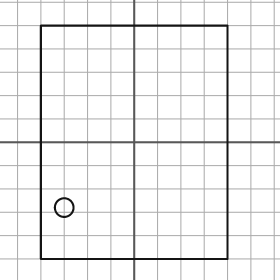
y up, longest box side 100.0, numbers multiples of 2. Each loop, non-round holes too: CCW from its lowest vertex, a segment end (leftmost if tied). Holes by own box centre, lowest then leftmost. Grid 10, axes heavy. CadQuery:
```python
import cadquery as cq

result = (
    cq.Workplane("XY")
    .moveTo(-40.0, -50.0)
    .lineTo(40.0, -50.0)
    .lineTo(40.0, 50.0)
    .lineTo(-40.0, 50.0)
    .close()
    .moveTo(-30.0, -28.0)
    .circle(4.0)
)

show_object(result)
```